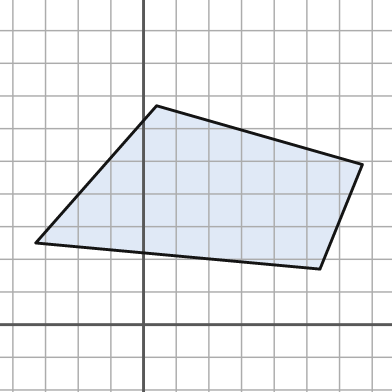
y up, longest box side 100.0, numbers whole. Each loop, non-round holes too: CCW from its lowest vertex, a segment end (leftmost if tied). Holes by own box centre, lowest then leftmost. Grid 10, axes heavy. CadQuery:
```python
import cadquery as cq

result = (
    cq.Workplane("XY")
    .moveTo(54.0, 17.0)
    .lineTo(67.0, 49.0)
    .lineTo(4.0, 67.0)
    .lineTo(-33.0, 25.0)
    .close()
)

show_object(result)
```